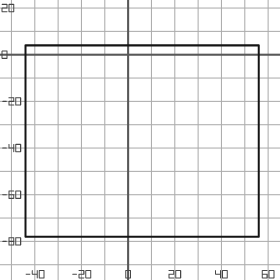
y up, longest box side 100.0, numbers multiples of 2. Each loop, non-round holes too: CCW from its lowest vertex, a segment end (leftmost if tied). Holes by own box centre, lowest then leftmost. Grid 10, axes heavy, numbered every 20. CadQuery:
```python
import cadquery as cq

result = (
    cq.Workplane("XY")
    .moveTo(-44.0, -78.0)
    .lineTo(56.0, -78.0)
    .lineTo(56.0, 4.0)
    .lineTo(-44.0, 4.0)
    .close()
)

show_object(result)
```